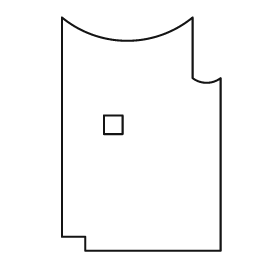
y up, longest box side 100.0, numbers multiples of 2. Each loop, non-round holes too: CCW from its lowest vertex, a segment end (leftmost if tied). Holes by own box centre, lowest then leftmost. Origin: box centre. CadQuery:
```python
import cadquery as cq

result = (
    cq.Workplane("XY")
    .moveTo(-24.0, -50.0)
    .lineTo(34.0, -50.0)
    .lineTo(34.0, 24.0)
    .threePointArc((28.0, 22.0), (22.0, 24.0))
    .lineTo(22.0, 50.0)
    .threePointArc((-6.0, 40.0), (-34.0, 50.0))
    .lineTo(-34.0, -44.0)
    .lineTo(-24.0, -44.0)
    .close()
    .moveTo(-16.0, 0.0)
    .lineTo(-8.0, 0.0)
    .lineTo(-8.0, 8.0)
    .lineTo(-16.0, 8.0)
    .close()
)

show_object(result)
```